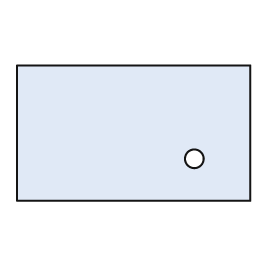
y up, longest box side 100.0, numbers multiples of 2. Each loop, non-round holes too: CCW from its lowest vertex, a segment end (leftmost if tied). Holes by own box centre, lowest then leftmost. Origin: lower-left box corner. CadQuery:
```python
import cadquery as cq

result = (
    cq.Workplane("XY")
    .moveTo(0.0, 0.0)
    .lineTo(100.0, 0.0)
    .lineTo(100.0, 58.0)
    .lineTo(0.0, 58.0)
    .close()
    .moveTo(76.0, 18.0)
    .circle(4.0)
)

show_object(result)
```